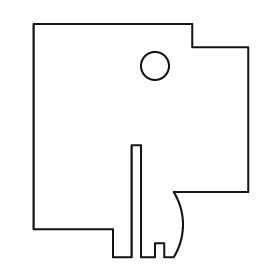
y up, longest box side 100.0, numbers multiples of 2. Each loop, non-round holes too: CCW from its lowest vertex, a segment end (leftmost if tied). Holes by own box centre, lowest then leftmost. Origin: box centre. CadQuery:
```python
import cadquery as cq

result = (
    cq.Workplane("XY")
    .moveTo(-12.0, -50.0)
    .lineTo(-4.0, -50.0)
    .lineTo(-4.0, -2.0)
    .lineTo(0.0, -2.0)
    .lineTo(0.0, -50.0)
    .lineTo(6.0, -50.0)
    .lineTo(6.0, -44.0)
    .lineTo(10.0, -44.0)
    .lineTo(10.0, -50.0)
    .lineTo(14.0, -50.0)
    .threePointArc((18.0, -36.0), (14.0, -22.0))
    .lineTo(46.0, -22.0)
    .lineTo(46.0, 40.0)
    .lineTo(22.0, 40.0)
    .lineTo(22.0, 50.0)
    .lineTo(-46.0, 50.0)
    .lineTo(-46.0, -38.0)
    .lineTo(-12.0, -38.0)
    .close()
    .moveTo(6.0, 32.0)
    .circle(6.0)
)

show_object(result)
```